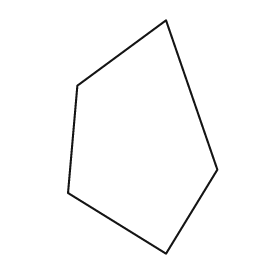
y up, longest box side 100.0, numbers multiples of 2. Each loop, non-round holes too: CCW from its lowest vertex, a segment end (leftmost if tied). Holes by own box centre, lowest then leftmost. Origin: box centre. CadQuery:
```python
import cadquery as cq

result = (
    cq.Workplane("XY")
    .moveTo(10.0, -50.0)
    .lineTo(32.0, -14.0)
    .lineTo(10.0, 50.0)
    .lineTo(-28.0, 22.0)
    .lineTo(-32.0, -24.0)
    .close()
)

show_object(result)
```